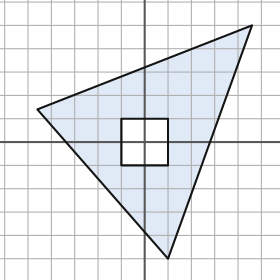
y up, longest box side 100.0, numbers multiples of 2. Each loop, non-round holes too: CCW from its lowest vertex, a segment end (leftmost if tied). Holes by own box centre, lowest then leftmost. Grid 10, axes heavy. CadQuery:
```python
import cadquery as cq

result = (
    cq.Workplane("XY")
    .moveTo(10.0, -50.0)
    .lineTo(46.0, 50.0)
    .lineTo(-46.0, 14.0)
    .close()
    .moveTo(-10.0, -10.0)
    .lineTo(10.0, -10.0)
    .lineTo(10.0, 10.0)
    .lineTo(-10.0, 10.0)
    .close()
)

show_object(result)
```